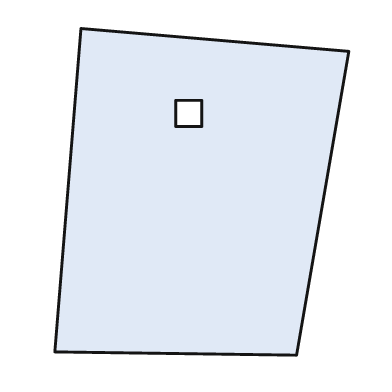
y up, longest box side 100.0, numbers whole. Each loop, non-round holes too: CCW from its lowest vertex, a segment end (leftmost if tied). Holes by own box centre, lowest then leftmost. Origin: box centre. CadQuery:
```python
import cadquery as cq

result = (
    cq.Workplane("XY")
    .moveTo(29.0, -50.0)
    .lineTo(45.0, 43.0)
    .lineTo(-37.0, 50.0)
    .lineTo(-45.0, -49.0)
    .close()
    .moveTo(-8.0, 20.0)
    .lineTo(0.0, 20.0)
    .lineTo(0.0, 28.0)
    .lineTo(-8.0, 28.0)
    .close()
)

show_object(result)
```